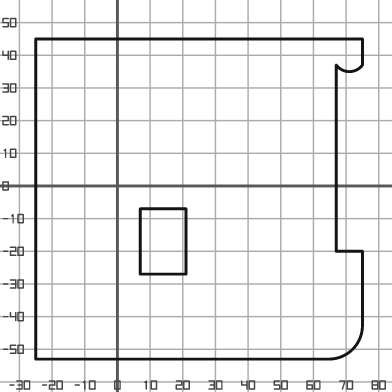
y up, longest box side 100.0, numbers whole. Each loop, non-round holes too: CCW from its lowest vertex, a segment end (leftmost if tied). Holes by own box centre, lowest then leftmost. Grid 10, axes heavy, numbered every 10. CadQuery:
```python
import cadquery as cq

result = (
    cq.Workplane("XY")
    .moveTo(-25.0, -53.0)
    .lineTo(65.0, -53.0)
    .threePointArc((72.0, -50.0), (75.0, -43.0))
    .lineTo(75.0, -20.0)
    .lineTo(67.0, -20.0)
    .lineTo(67.0, 37.0)
    .threePointArc((71.0, 35.0), (75.0, 37.0))
    .lineTo(75.0, 45.0)
    .lineTo(-25.0, 45.0)
    .close()
    .moveTo(7.0, -27.0)
    .lineTo(21.0, -27.0)
    .lineTo(21.0, -7.0)
    .lineTo(7.0, -7.0)
    .close()
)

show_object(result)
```